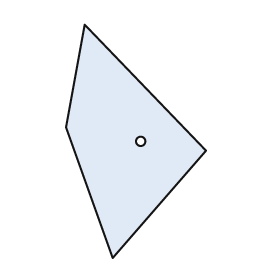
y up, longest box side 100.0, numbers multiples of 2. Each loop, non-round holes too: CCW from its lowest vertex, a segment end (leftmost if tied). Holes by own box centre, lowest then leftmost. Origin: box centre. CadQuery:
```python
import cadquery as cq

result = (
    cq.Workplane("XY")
    .moveTo(-10.0, -50.0)
    .lineTo(30.0, -4.0)
    .lineTo(-22.0, 50.0)
    .lineTo(-30.0, 6.0)
    .close()
    .moveTo(2.0, 0.0)
    .circle(2.0)
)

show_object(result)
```